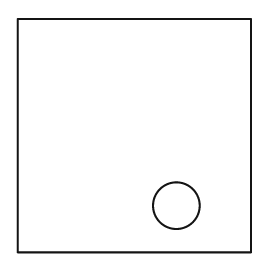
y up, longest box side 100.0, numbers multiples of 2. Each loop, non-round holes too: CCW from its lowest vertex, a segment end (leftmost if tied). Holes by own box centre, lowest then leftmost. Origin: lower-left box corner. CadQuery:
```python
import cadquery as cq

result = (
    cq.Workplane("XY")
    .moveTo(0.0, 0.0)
    .lineTo(100.0, 0.0)
    .lineTo(100.0, 100.0)
    .lineTo(0.0, 100.0)
    .close()
    .moveTo(68.0, 20.0)
    .circle(10.0)
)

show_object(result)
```